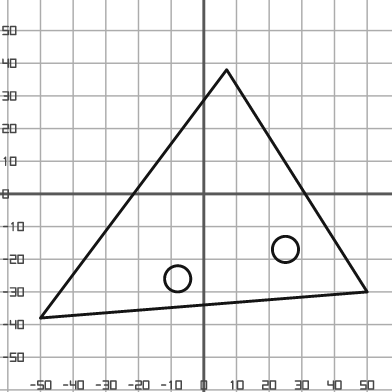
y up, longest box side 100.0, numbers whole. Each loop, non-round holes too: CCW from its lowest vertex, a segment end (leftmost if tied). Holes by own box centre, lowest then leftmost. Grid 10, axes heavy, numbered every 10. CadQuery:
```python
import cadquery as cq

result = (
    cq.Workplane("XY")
    .moveTo(-50.0, -38.0)
    .lineTo(50.0, -30.0)
    .lineTo(7.0, 38.0)
    .close()
    .moveTo(-8.0, -26.0)
    .circle(4.0)
    .moveTo(25.0, -17.0)
    .circle(4.0)
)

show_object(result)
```